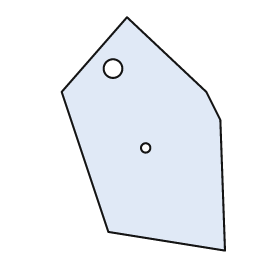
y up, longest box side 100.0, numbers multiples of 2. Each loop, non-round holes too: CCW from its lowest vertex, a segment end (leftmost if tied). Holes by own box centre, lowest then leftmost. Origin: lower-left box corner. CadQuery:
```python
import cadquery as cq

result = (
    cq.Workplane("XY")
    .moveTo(70.0, 0.0)
    .lineTo(68.0, 56.0)
    .lineTo(62.0, 68.0)
    .lineTo(28.0, 100.0)
    .lineTo(0.0, 68.0)
    .lineTo(20.0, 8.0)
    .close()
    .moveTo(36.0, 44.0)
    .circle(2.0)
    .moveTo(22.0, 78.0)
    .circle(4.0)
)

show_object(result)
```